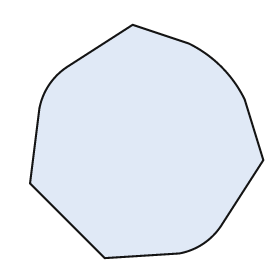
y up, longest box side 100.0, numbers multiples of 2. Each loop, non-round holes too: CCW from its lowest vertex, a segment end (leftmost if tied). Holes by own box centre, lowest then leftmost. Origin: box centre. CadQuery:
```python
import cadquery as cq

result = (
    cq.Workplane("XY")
    .moveTo(-18.0, -50.0)
    .lineTo(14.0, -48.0)
    .threePointArc((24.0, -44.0), (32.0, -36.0))
    .lineTo(50.0, -8.0)
    .lineTo(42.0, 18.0)
    .threePointArc((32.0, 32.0), (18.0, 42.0))
    .lineTo(-6.0, 50.0)
    .lineTo(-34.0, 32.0)
    .threePointArc((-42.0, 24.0), (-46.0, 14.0))
    .lineTo(-50.0, -18.0)
    .close()
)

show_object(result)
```